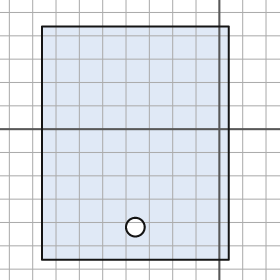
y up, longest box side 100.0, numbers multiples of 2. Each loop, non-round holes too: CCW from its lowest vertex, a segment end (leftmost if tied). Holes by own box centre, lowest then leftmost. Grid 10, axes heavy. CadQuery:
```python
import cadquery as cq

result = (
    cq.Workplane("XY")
    .moveTo(-76.0, -56.0)
    .lineTo(4.0, -56.0)
    .lineTo(4.0, 44.0)
    .lineTo(-76.0, 44.0)
    .close()
    .moveTo(-36.0, -42.0)
    .circle(4.0)
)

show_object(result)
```